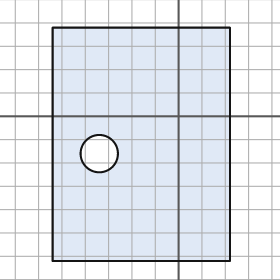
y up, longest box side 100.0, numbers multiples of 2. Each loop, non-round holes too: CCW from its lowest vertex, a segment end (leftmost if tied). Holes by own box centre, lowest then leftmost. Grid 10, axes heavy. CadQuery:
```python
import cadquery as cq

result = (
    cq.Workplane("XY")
    .moveTo(-54.0, -62.0)
    .lineTo(22.0, -62.0)
    .lineTo(22.0, 38.0)
    .lineTo(-54.0, 38.0)
    .close()
    .moveTo(-34.0, -16.0)
    .circle(8.0)
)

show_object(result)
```